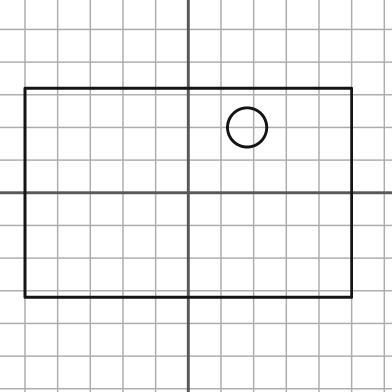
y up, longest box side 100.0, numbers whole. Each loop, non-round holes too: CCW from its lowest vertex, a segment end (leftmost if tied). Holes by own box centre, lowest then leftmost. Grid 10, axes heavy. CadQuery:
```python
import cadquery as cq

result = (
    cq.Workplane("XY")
    .moveTo(-50.0, -32.0)
    .lineTo(50.0, -32.0)
    .lineTo(50.0, 32.0)
    .lineTo(-50.0, 32.0)
    .close()
    .moveTo(18.0, 20.0)
    .circle(6.0)
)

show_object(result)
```